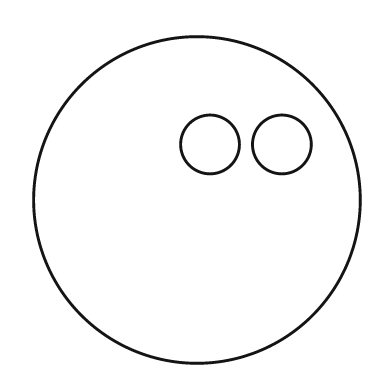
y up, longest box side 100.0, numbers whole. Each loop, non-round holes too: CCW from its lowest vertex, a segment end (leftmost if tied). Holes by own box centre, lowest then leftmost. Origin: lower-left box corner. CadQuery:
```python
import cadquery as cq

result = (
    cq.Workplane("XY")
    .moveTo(50.0, 50.0)
    .circle(50.0)
    .moveTo(54.0, 67.0)
    .circle(9.0)
    .moveTo(76.0, 67.0)
    .circle(9.0)
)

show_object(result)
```